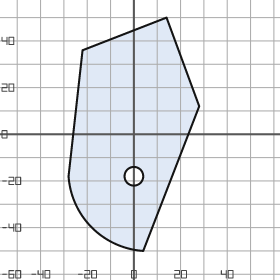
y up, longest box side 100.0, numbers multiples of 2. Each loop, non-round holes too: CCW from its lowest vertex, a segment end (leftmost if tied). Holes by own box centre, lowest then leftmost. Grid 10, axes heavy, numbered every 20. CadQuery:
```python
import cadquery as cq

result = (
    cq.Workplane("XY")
    .moveTo(4.0, -50.0)
    .lineTo(28.0, 12.0)
    .lineTo(14.0, 50.0)
    .lineTo(-22.0, 36.0)
    .lineTo(-28.0, -18.0)
    .threePointArc((-18.0, -40.0), (4.0, -50.0))
    .close()
    .moveTo(0.0, -18.0)
    .circle(4.0)
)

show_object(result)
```